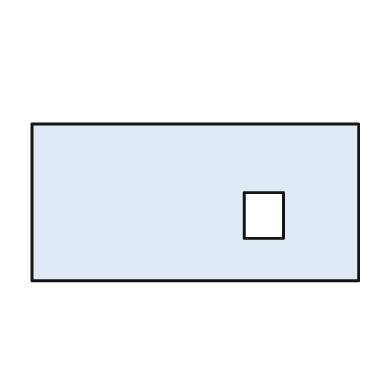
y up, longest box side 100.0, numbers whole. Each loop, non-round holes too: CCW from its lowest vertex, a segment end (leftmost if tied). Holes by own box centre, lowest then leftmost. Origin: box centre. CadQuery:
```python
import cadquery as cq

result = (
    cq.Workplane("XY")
    .moveTo(-50.0, -24.0)
    .lineTo(50.0, -24.0)
    .lineTo(50.0, 24.0)
    .lineTo(-50.0, 24.0)
    .close()
    .moveTo(15.0, -11.0)
    .lineTo(27.0, -11.0)
    .lineTo(27.0, 3.0)
    .lineTo(15.0, 3.0)
    .close()
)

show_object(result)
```